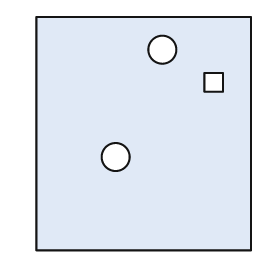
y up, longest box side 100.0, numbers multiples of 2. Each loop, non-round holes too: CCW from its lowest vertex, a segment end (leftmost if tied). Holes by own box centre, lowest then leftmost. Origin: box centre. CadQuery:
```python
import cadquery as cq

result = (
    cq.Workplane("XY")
    .moveTo(-46.0, -50.0)
    .lineTo(46.0, -50.0)
    .lineTo(46.0, 50.0)
    .lineTo(-46.0, 50.0)
    .close()
    .moveTo(-12.0, -10.0)
    .circle(6.0)
    .moveTo(26.0, 18.0)
    .lineTo(34.0, 18.0)
    .lineTo(34.0, 26.0)
    .lineTo(26.0, 26.0)
    .close()
    .moveTo(8.0, 36.0)
    .circle(6.0)
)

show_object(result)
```